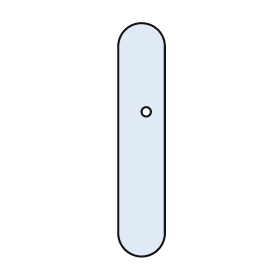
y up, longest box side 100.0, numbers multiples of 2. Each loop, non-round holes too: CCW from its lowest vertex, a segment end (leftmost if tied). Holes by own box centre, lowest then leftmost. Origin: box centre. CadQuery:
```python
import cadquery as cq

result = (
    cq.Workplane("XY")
    .moveTo(-10.0, -40.0)
    .threePointArc((0.0, -50.0), (10.0, -40.0))
    .lineTo(10.0, 40.0)
    .threePointArc((0.0, 50.0), (-10.0, 40.0))
    .close()
    .moveTo(2.0, 12.0)
    .circle(2.0)
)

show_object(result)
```